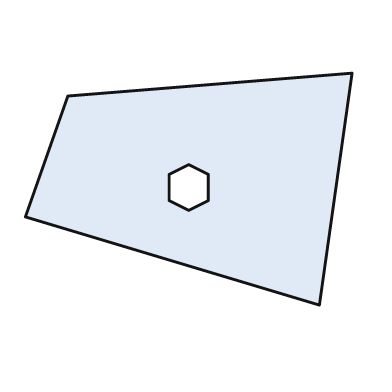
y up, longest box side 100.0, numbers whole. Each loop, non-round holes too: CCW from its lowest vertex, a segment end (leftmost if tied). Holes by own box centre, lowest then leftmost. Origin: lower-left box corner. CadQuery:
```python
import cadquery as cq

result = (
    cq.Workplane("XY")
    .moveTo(90.0, 0.0)
    .lineTo(100.0, 71.0)
    .lineTo(13.0, 64.0)
    .lineTo(0.0, 27.0)
    .close()
    .moveTo(50.0, 29.0)
    .lineTo(56.0, 32.0)
    .lineTo(56.0, 40.0)
    .lineTo(50.0, 43.0)
    .lineTo(44.0, 40.0)
    .lineTo(44.0, 32.0)
    .close()
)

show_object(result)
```